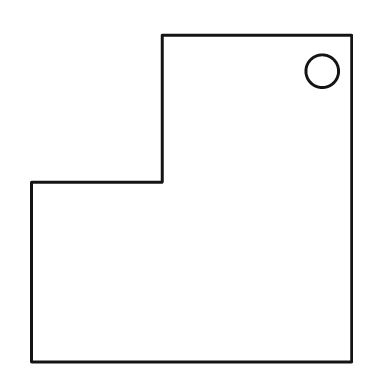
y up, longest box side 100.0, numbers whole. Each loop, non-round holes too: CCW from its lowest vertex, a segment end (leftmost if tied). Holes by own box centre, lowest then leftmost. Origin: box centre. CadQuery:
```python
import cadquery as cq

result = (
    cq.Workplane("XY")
    .moveTo(-49.0, -50.0)
    .lineTo(49.0, -50.0)
    .lineTo(49.0, 50.0)
    .lineTo(-9.0, 50.0)
    .lineTo(-9.0, 5.0)
    .lineTo(-49.0, 5.0)
    .close()
    .moveTo(40.0, 39.0)
    .circle(5.0)
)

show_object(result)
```